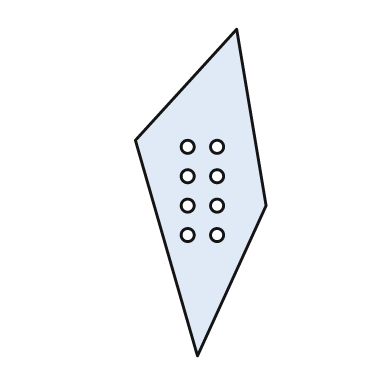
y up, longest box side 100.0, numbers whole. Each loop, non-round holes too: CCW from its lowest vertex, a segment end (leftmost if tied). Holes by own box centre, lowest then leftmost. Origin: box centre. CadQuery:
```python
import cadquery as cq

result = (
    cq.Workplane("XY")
    .moveTo(-1.0, -50.0)
    .lineTo(20.0, -4.0)
    .lineTo(11.0, 50.0)
    .lineTo(-20.0, 16.0)
    .close()
    .moveTo(-4.0, -13.0)
    .circle(2.0)
    .moveTo(5.0, -13.0)
    .circle(2.0)
    .moveTo(-4.0, -4.0)
    .circle(2.0)
    .moveTo(5.0, -4.0)
    .circle(2.0)
    .moveTo(-4.0, 5.0)
    .circle(2.0)
    .moveTo(5.0, 5.0)
    .circle(2.0)
    .moveTo(-4.0, 14.0)
    .circle(2.0)
    .moveTo(5.0, 14.0)
    .circle(2.0)
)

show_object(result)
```